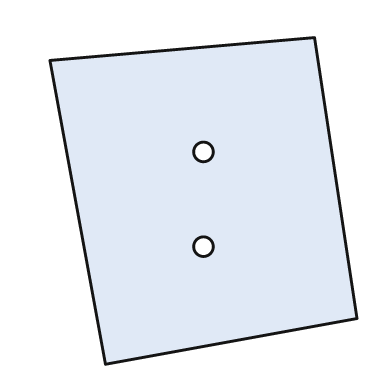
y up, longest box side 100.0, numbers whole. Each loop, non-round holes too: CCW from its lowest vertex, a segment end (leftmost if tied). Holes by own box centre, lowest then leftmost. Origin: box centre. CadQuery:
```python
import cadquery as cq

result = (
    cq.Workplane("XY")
    .moveTo(-30.0, -50.0)
    .lineTo(47.0, -36.0)
    .lineTo(34.0, 50.0)
    .lineTo(-47.0, 43.0)
    .close()
    .moveTo(0.0, -14.0)
    .circle(3.0)
    .moveTo(0.0, 15.0)
    .circle(3.0)
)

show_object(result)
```